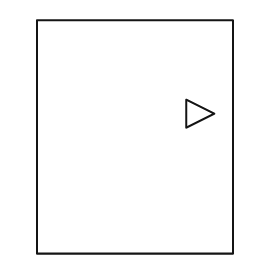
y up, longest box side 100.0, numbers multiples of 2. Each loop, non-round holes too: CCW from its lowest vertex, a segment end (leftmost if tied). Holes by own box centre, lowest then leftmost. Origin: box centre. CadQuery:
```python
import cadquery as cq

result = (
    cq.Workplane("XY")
    .moveTo(-42.0, -50.0)
    .lineTo(42.0, -50.0)
    .lineTo(42.0, 50.0)
    .lineTo(-42.0, 50.0)
    .close()
    .moveTo(22.0, 4.0)
    .lineTo(34.0, 10.0)
    .lineTo(22.0, 16.0)
    .close()
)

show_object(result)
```